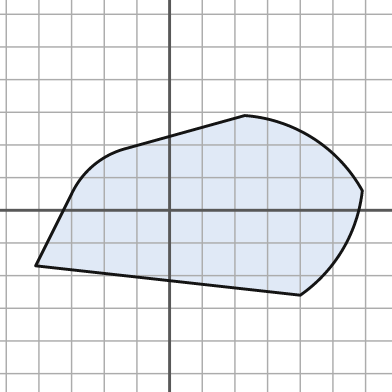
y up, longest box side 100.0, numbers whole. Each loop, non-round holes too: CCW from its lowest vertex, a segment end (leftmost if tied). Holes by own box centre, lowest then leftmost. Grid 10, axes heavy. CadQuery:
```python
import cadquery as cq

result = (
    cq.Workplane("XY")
    .moveTo(40.0, -26.0)
    .threePointArc((53.0, -12.0), (59.0, 6.0))
    .threePointArc((44.0, 22.0), (23.0, 29.0))
    .lineTo(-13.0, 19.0)
    .threePointArc((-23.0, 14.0), (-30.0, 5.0))
    .lineTo(-41.0, -17.0)
    .close()
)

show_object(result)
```